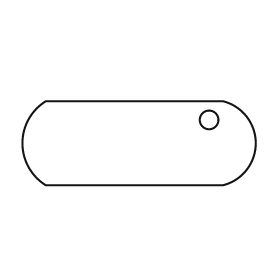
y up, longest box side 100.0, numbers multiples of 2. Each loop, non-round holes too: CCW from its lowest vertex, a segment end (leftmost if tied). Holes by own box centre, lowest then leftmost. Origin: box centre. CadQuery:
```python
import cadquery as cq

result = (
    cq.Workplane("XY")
    .moveTo(-40.0, -18.0)
    .lineTo(36.0, -18.0)
    .threePointArc((50.0, 0.0), (36.0, 18.0))
    .lineTo(-40.0, 18.0)
    .threePointArc((-50.0, 0.0), (-40.0, -18.0))
    .close()
    .moveTo(30.0, 10.0)
    .circle(4.0)
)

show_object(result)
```